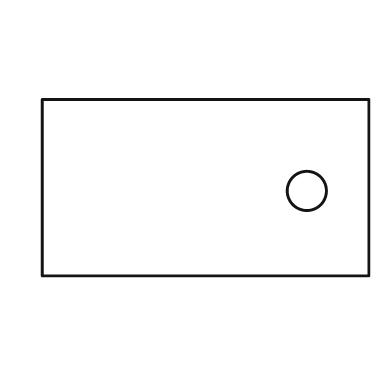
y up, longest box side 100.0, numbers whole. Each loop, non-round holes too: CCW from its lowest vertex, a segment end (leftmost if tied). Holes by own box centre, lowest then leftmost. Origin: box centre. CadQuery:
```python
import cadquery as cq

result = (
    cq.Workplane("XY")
    .moveTo(-50.0, -27.0)
    .lineTo(50.0, -27.0)
    .lineTo(50.0, 27.0)
    .lineTo(-50.0, 27.0)
    .close()
    .moveTo(31.0, -1.0)
    .circle(6.0)
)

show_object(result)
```